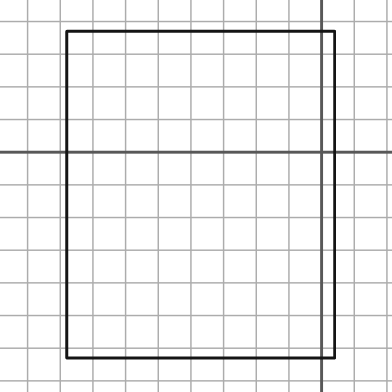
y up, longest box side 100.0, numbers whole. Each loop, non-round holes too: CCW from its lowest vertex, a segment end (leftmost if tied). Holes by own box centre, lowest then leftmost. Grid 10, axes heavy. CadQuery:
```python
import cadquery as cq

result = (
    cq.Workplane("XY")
    .moveTo(-78.0, -63.0)
    .lineTo(4.0, -63.0)
    .lineTo(4.0, 37.0)
    .lineTo(-78.0, 37.0)
    .close()
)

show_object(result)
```